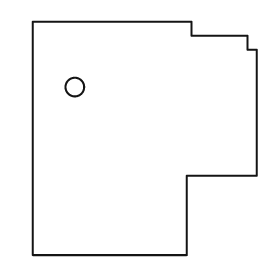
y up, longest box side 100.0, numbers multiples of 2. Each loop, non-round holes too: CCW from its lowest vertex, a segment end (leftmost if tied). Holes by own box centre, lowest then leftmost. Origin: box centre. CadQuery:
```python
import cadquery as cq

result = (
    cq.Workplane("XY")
    .moveTo(-48.0, -50.0)
    .lineTo(18.0, -50.0)
    .lineTo(18.0, -16.0)
    .lineTo(48.0, -16.0)
    .lineTo(48.0, 38.0)
    .lineTo(44.0, 38.0)
    .lineTo(44.0, 44.0)
    .lineTo(20.0, 44.0)
    .lineTo(20.0, 50.0)
    .lineTo(-48.0, 50.0)
    .close()
    .moveTo(-30.0, 22.0)
    .circle(4.0)
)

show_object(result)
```